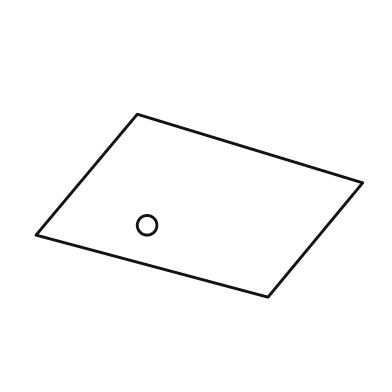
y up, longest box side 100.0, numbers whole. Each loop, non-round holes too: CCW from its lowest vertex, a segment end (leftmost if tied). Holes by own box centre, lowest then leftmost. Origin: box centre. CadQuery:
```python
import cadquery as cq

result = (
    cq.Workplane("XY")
    .moveTo(21.0, -28.0)
    .lineTo(50.0, 7.0)
    .lineTo(-19.0, 28.0)
    .lineTo(-50.0, -9.0)
    .close()
    .moveTo(-16.0, -6.0)
    .circle(3.0)
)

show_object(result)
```